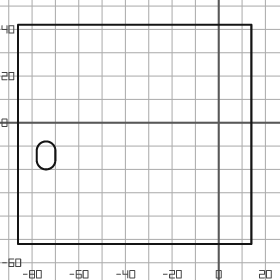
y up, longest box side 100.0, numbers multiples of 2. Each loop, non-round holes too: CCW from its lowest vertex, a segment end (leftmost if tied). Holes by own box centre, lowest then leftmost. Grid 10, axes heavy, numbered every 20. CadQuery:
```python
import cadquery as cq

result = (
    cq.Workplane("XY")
    .moveTo(-86.0, -52.0)
    .lineTo(14.0, -52.0)
    .lineTo(14.0, 42.0)
    .lineTo(-86.0, 42.0)
    .close()
    .moveTo(-78.0, -16.0)
    .threePointArc((-74.0, -20.0), (-70.0, -16.0))
    .lineTo(-70.0, -12.0)
    .threePointArc((-74.0, -8.0), (-78.0, -12.0))
    .close()
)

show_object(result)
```